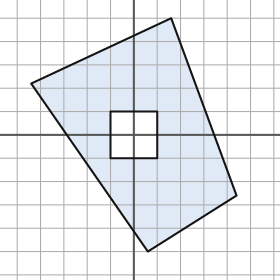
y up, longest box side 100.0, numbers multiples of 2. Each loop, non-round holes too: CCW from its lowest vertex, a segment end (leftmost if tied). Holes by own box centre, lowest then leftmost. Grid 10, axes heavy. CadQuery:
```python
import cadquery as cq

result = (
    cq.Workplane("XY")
    .moveTo(6.0, -50.0)
    .lineTo(44.0, -26.0)
    .lineTo(16.0, 50.0)
    .lineTo(-44.0, 22.0)
    .close()
    .moveTo(-10.0, -10.0)
    .lineTo(10.0, -10.0)
    .lineTo(10.0, 10.0)
    .lineTo(-10.0, 10.0)
    .close()
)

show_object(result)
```